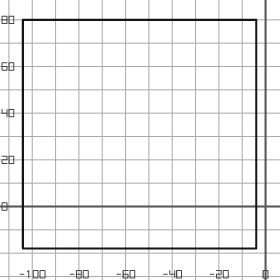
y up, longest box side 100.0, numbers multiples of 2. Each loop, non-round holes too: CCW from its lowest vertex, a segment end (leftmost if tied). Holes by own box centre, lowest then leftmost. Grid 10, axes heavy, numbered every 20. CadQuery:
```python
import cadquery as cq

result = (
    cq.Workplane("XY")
    .moveTo(-104.0, -18.0)
    .lineTo(-4.0, -18.0)
    .lineTo(-4.0, 80.0)
    .lineTo(-104.0, 80.0)
    .close()
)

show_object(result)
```